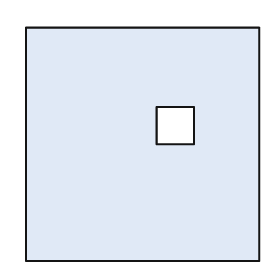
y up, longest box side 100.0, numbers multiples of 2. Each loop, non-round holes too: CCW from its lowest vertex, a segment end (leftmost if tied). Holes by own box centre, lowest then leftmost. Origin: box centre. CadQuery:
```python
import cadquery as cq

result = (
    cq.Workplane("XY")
    .moveTo(-50.0, -50.0)
    .lineTo(50.0, -50.0)
    .lineTo(50.0, 50.0)
    .lineTo(-50.0, 50.0)
    .close()
    .moveTo(6.0, 0.0)
    .lineTo(22.0, 0.0)
    .lineTo(22.0, 16.0)
    .lineTo(6.0, 16.0)
    .close()
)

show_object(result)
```